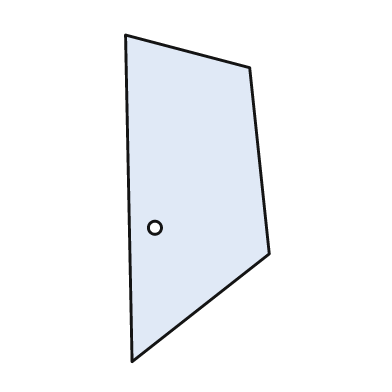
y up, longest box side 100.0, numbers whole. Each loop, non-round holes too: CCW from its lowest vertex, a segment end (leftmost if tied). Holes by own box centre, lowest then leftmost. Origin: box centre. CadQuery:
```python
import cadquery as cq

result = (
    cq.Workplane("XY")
    .moveTo(-20.0, -50.0)
    .lineTo(22.0, -17.0)
    .lineTo(16.0, 40.0)
    .lineTo(-22.0, 50.0)
    .close()
    .moveTo(-13.0, -9.0)
    .circle(2.0)
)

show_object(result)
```